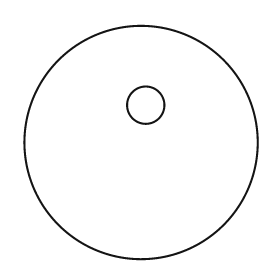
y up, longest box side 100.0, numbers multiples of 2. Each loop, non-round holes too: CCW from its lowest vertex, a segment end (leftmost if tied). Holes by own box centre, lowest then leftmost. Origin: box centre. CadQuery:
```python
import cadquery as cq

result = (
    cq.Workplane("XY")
    .moveTo(0.0, 0.0)
    .circle(50.0)
    .moveTo(2.0, 16.0)
    .circle(8.0)
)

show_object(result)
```